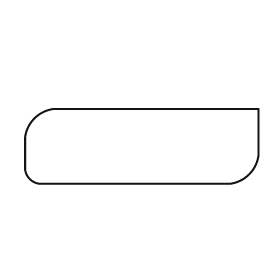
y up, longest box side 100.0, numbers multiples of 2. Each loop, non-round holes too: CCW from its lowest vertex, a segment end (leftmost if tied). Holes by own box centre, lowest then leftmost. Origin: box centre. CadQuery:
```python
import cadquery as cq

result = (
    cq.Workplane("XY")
    .moveTo(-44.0, -16.0)
    .lineTo(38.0, -16.0)
    .threePointArc((46.0, -12.0), (50.0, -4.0))
    .lineTo(50.0, 16.0)
    .lineTo(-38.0, 16.0)
    .threePointArc((-46.0, 12.0), (-50.0, 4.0))
    .lineTo(-50.0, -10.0)
    .threePointArc((-48.0, -14.0), (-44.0, -16.0))
    .close()
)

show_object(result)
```